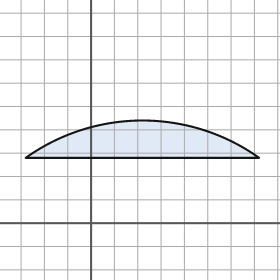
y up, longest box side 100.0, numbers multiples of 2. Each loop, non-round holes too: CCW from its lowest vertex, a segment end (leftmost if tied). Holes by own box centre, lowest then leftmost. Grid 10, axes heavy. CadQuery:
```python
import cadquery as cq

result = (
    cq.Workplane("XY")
    .moveTo(-28.0, 28.0)
    .lineTo(72.0, 28.0)
    .threePointArc((22.0, 44.0), (-28.0, 28.0))
    .close()
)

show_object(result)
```